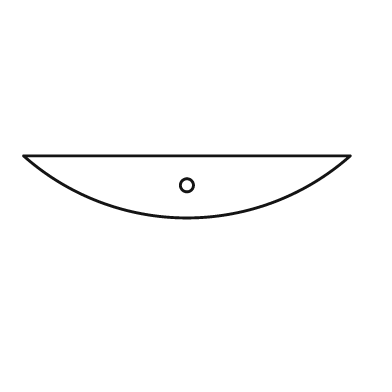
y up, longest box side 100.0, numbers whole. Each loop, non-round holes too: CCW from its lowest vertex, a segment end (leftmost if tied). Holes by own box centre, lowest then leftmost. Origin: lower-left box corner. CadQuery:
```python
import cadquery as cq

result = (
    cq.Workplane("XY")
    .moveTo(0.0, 19.0)
    .threePointArc((50.0, 0.0), (100.0, 19.0))
    .close()
    .moveTo(50.0, 10.0)
    .circle(2.0)
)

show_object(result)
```